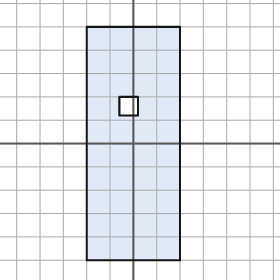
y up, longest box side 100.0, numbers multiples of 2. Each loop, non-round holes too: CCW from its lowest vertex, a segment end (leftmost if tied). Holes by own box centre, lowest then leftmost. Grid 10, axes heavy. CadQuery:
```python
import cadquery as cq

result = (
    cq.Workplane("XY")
    .moveTo(-20.0, -50.0)
    .lineTo(20.0, -50.0)
    .lineTo(20.0, 50.0)
    .lineTo(-20.0, 50.0)
    .close()
    .moveTo(-6.0, 12.0)
    .lineTo(2.0, 12.0)
    .lineTo(2.0, 20.0)
    .lineTo(-6.0, 20.0)
    .close()
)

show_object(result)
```